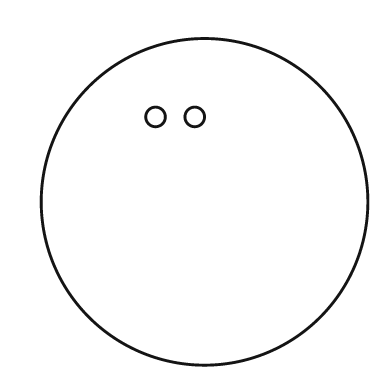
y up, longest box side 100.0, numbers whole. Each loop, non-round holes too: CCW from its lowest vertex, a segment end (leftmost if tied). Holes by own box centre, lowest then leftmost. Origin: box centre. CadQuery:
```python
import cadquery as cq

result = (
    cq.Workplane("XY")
    .moveTo(0.0, 0.0)
    .circle(50.0)
    .moveTo(-15.0, 26.0)
    .circle(3.0)
    .moveTo(-3.0, 26.0)
    .circle(3.0)
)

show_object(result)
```